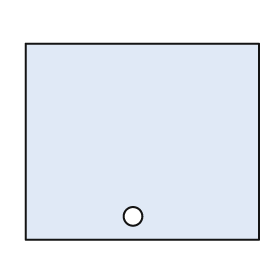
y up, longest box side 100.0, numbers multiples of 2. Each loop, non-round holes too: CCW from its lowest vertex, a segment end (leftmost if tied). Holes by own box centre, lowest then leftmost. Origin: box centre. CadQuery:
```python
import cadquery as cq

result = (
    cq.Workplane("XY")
    .moveTo(-50.0, -42.0)
    .lineTo(50.0, -42.0)
    .lineTo(50.0, 42.0)
    .lineTo(-50.0, 42.0)
    .close()
    .moveTo(-4.0, -32.0)
    .circle(4.0)
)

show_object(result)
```